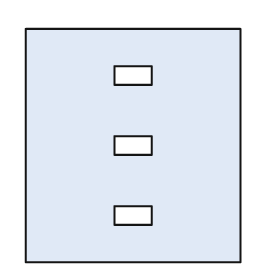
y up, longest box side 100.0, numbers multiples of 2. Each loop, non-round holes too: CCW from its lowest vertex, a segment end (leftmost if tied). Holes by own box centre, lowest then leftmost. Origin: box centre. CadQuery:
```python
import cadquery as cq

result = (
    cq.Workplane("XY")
    .moveTo(-46.0, -50.0)
    .lineTo(46.0, -50.0)
    .lineTo(46.0, 50.0)
    .lineTo(-46.0, 50.0)
    .close()
    .moveTo(-8.0, -34.0)
    .lineTo(8.0, -34.0)
    .lineTo(8.0, -26.0)
    .lineTo(-8.0, -26.0)
    .close()
    .moveTo(-8.0, -4.0)
    .lineTo(8.0, -4.0)
    .lineTo(8.0, 4.0)
    .lineTo(-8.0, 4.0)
    .close()
    .moveTo(-8.0, 26.0)
    .lineTo(8.0, 26.0)
    .lineTo(8.0, 34.0)
    .lineTo(-8.0, 34.0)
    .close()
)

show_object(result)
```